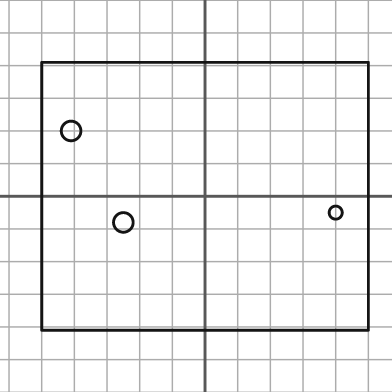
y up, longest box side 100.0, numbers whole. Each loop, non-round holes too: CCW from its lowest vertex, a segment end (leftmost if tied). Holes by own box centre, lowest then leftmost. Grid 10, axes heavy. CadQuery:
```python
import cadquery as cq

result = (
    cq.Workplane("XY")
    .moveTo(-50.0, -41.0)
    .lineTo(50.0, -41.0)
    .lineTo(50.0, 41.0)
    .lineTo(-50.0, 41.0)
    .close()
    .moveTo(-25.0, -8.0)
    .circle(3.0)
    .moveTo(40.0, -5.0)
    .circle(2.0)
    .moveTo(-41.0, 20.0)
    .circle(3.0)
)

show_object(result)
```